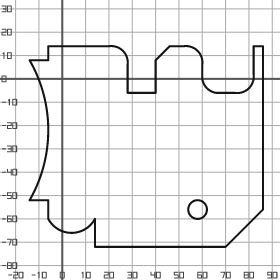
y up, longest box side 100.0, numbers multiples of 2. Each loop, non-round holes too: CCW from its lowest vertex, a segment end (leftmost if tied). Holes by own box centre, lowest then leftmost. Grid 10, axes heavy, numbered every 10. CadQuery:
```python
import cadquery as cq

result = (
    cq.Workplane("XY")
    .moveTo(14.0, -72.0)
    .lineTo(70.0, -72.0)
    .lineTo(86.0, -56.0)
    .lineTo(86.0, 14.0)
    .lineTo(82.0, 14.0)
    .lineTo(82.0, 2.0)
    .threePointArc((80.0, -4.0), (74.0, -6.0))
    .lineTo(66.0, -6.0)
    .threePointArc((62.0, -4.0), (60.0, 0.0))
    .lineTo(60.0, 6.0)
    .threePointArc((58.0, 12.0), (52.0, 14.0))
    .lineTo(46.0, 14.0)
    .lineTo(40.0, 8.0)
    .lineTo(40.0, -6.0)
    .lineTo(28.0, -6.0)
    .lineTo(28.0, 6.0)
    .threePointArc((26.0, 12.0), (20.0, 14.0))
    .lineTo(-6.0, 14.0)
    .lineTo(-6.0, 8.0)
    .lineTo(-14.0, 8.0)
    .threePointArc((-6.0, -22.0), (-14.0, -52.0))
    .lineTo(-6.0, -52.0)
    .lineTo(-6.0, -60.0)
    .threePointArc((4.0, -66.0), (14.0, -60.0))
    .close()
    .moveTo(58.0, -56.0)
    .circle(4.0)
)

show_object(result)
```